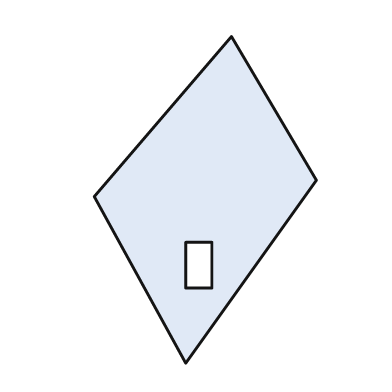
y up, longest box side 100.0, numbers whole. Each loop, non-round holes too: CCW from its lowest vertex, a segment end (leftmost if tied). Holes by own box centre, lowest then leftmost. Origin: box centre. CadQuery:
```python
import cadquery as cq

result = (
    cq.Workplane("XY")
    .moveTo(-6.0, -50.0)
    .lineTo(34.0, 6.0)
    .lineTo(8.0, 50.0)
    .lineTo(-34.0, 1.0)
    .close()
    .moveTo(-6.0, -27.0)
    .lineTo(2.0, -27.0)
    .lineTo(2.0, -13.0)
    .lineTo(-6.0, -13.0)
    .close()
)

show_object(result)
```